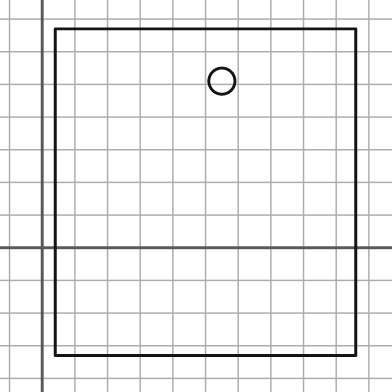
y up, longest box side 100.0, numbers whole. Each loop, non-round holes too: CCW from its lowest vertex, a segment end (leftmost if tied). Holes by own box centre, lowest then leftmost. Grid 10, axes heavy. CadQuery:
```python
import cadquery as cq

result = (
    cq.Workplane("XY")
    .moveTo(4.0, -33.0)
    .lineTo(96.0, -33.0)
    .lineTo(96.0, 67.0)
    .lineTo(4.0, 67.0)
    .close()
    .moveTo(55.0, 51.0)
    .circle(4.0)
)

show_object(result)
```